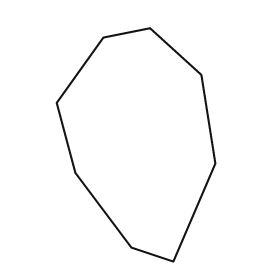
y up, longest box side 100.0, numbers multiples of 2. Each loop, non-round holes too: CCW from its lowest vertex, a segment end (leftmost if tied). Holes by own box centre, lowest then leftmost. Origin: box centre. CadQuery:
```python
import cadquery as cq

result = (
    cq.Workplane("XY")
    .moveTo(16.0, -50.0)
    .lineTo(34.0, -8.0)
    .lineTo(28.0, 30.0)
    .lineTo(6.0, 50.0)
    .lineTo(-14.0, 46.0)
    .lineTo(-34.0, 18.0)
    .lineTo(-26.0, -12.0)
    .lineTo(-2.0, -44.0)
    .close()
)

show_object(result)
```